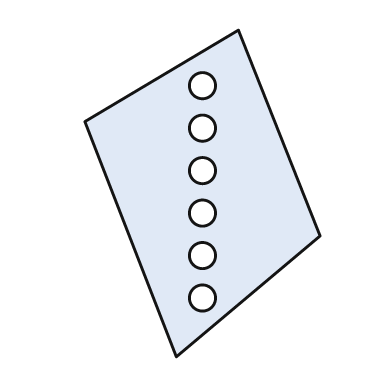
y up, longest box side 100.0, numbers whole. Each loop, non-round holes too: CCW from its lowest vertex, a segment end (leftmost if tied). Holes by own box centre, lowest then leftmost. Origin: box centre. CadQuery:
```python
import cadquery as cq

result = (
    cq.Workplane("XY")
    .moveTo(-8.0, -50.0)
    .lineTo(36.0, -13.0)
    .lineTo(11.0, 50.0)
    .lineTo(-36.0, 22.0)
    .close()
    .moveTo(0.0, -32.0)
    .circle(4.0)
    .moveTo(0.0, -19.0)
    .circle(4.0)
    .moveTo(0.0, -6.0)
    .circle(4.0)
    .moveTo(0.0, 7.0)
    .circle(4.0)
    .moveTo(0.0, 20.0)
    .circle(4.0)
    .moveTo(0.0, 33.0)
    .circle(4.0)
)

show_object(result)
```